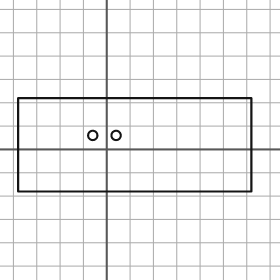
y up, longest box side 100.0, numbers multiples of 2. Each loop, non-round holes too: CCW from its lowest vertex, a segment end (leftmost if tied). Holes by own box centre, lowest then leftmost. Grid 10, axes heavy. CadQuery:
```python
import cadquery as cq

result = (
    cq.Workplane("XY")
    .moveTo(-38.0, -18.0)
    .lineTo(62.0, -18.0)
    .lineTo(62.0, 22.0)
    .lineTo(-38.0, 22.0)
    .close()
    .moveTo(-6.0, 6.0)
    .circle(2.0)
    .moveTo(4.0, 6.0)
    .circle(2.0)
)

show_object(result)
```